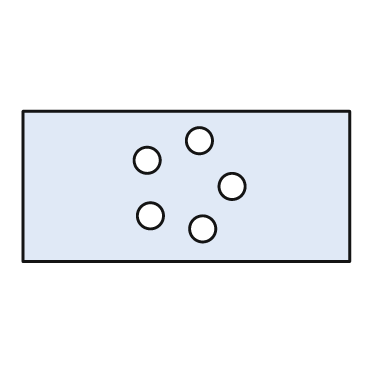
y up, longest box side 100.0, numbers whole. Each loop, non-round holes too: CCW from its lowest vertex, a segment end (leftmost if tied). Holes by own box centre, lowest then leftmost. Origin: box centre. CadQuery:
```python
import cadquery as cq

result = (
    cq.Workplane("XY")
    .moveTo(-50.0, -23.0)
    .lineTo(50.0, -23.0)
    .lineTo(50.0, 23.0)
    .lineTo(-50.0, 23.0)
    .close()
    .moveTo(5.0, -13.0)
    .circle(4.0)
    .moveTo(-11.0, -9.0)
    .circle(4.0)
    .moveTo(14.0, 0.0)
    .circle(4.0)
    .moveTo(-12.0, 8.0)
    .circle(4.0)
    .moveTo(4.0, 14.0)
    .circle(4.0)
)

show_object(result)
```